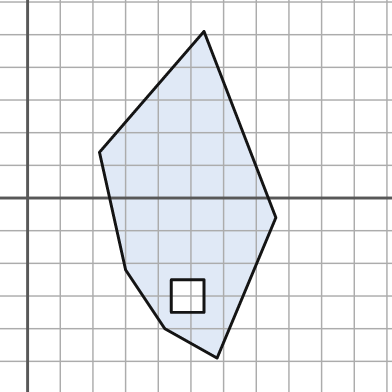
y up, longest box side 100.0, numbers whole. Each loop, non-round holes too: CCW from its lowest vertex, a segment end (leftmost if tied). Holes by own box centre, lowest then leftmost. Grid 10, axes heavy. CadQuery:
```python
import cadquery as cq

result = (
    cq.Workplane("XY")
    .moveTo(58.0, -49.0)
    .lineTo(76.0, -6.0)
    .lineTo(54.0, 51.0)
    .lineTo(22.0, 14.0)
    .lineTo(30.0, -22.0)
    .lineTo(42.0, -40.0)
    .close()
    .moveTo(44.0, -35.0)
    .lineTo(54.0, -35.0)
    .lineTo(54.0, -25.0)
    .lineTo(44.0, -25.0)
    .close()
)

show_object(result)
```